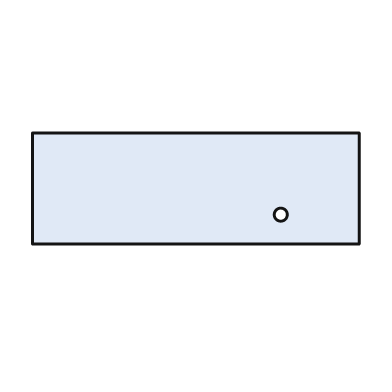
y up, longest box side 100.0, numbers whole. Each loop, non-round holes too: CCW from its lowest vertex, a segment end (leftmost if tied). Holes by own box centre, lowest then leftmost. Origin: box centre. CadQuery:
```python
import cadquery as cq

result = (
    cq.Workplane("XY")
    .moveTo(-50.0, -17.0)
    .lineTo(50.0, -17.0)
    .lineTo(50.0, 17.0)
    .lineTo(-50.0, 17.0)
    .close()
    .moveTo(26.0, -8.0)
    .circle(2.0)
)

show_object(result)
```